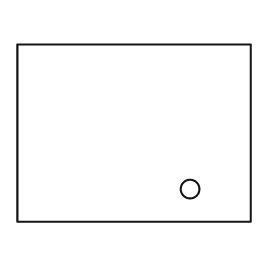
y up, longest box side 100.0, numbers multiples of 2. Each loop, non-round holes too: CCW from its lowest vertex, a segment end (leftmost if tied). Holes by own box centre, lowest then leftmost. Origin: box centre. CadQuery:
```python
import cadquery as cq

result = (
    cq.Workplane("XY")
    .moveTo(-50.0, -38.0)
    .lineTo(50.0, -38.0)
    .lineTo(50.0, 38.0)
    .lineTo(-50.0, 38.0)
    .close()
    .moveTo(24.0, -24.0)
    .circle(4.0)
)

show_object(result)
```